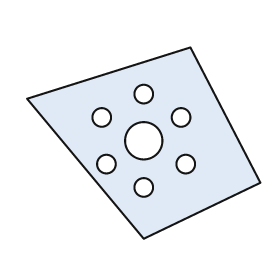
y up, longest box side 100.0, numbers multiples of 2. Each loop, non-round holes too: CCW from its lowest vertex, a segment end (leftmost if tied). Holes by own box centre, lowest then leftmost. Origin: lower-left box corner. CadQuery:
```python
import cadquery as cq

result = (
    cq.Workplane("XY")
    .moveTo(50.0, 0.0)
    .lineTo(100.0, 24.0)
    .lineTo(70.0, 82.0)
    .lineTo(0.0, 60.0)
    .close()
    .moveTo(50.0, 22.0)
    .circle(4.0)
    .moveTo(34.0, 32.0)
    .circle(4.0)
    .moveTo(68.0, 32.0)
    .circle(4.0)
    .moveTo(50.0, 42.0)
    .circle(8.0)
    .moveTo(32.0, 52.0)
    .circle(4.0)
    .moveTo(66.0, 52.0)
    .circle(4.0)
    .moveTo(50.0, 62.0)
    .circle(4.0)
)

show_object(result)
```